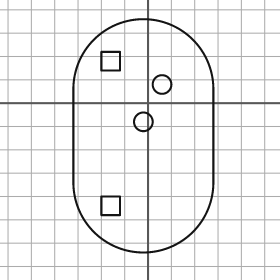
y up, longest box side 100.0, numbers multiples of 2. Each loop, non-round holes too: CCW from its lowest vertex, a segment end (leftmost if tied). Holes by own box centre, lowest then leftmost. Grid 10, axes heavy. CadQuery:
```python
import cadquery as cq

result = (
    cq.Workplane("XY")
    .moveTo(-32.0, -34.0)
    .threePointArc((-2.0, -64.0), (28.0, -34.0))
    .lineTo(28.0, 6.0)
    .threePointArc((-2.0, 36.0), (-32.0, 6.0))
    .close()
    .moveTo(-20.0, -48.0)
    .lineTo(-12.0, -48.0)
    .lineTo(-12.0, -40.0)
    .lineTo(-20.0, -40.0)
    .close()
    .moveTo(-2.0, -8.0)
    .circle(4.0)
    .moveTo(6.0, 8.0)
    .circle(4.0)
    .moveTo(-20.0, 14.0)
    .lineTo(-12.0, 14.0)
    .lineTo(-12.0, 22.0)
    .lineTo(-20.0, 22.0)
    .close()
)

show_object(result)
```